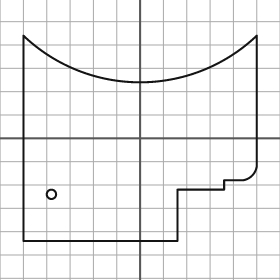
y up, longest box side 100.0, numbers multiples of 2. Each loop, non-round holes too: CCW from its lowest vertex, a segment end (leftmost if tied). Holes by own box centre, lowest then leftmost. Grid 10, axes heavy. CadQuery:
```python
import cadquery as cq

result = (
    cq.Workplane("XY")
    .moveTo(-50.0, -44.0)
    .lineTo(16.0, -44.0)
    .lineTo(16.0, -22.0)
    .lineTo(36.0, -22.0)
    .lineTo(36.0, -18.0)
    .lineTo(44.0, -18.0)
    .threePointArc((48.0, -16.0), (50.0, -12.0))
    .lineTo(50.0, 44.0)
    .threePointArc((0.0, 24.0), (-50.0, 44.0))
    .close()
    .moveTo(-38.0, -24.0)
    .circle(2.0)
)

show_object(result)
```